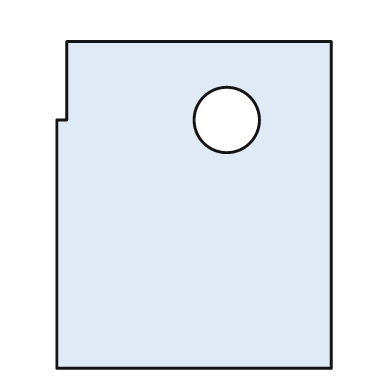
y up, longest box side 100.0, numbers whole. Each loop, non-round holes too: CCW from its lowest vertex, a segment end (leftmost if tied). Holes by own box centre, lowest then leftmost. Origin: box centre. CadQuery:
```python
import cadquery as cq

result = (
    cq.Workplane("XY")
    .moveTo(-42.0, -50.0)
    .lineTo(42.0, -50.0)
    .lineTo(42.0, 50.0)
    .lineTo(-39.0, 50.0)
    .lineTo(-39.0, 26.0)
    .lineTo(-42.0, 26.0)
    .close()
    .moveTo(10.0, 26.0)
    .circle(10.0)
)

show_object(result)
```